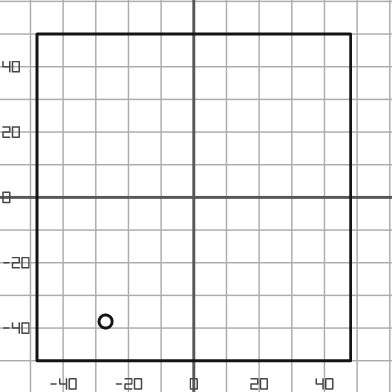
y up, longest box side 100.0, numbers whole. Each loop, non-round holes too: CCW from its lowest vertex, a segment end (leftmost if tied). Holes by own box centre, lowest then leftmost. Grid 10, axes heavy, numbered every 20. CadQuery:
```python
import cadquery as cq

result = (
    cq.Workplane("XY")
    .moveTo(-48.0, -50.0)
    .lineTo(48.0, -50.0)
    .lineTo(48.0, 50.0)
    .lineTo(-48.0, 50.0)
    .close()
    .moveTo(-27.0, -38.0)
    .circle(2.0)
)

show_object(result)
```